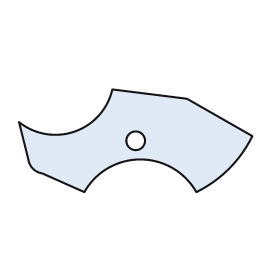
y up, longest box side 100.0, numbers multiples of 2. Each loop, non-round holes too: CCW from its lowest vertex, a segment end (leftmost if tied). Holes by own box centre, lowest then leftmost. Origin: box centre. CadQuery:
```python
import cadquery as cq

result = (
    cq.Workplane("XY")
    .moveTo(-22.0, -22.0)
    .threePointArc((2.0, -8.0), (26.0, -22.0))
    .threePointArc((40.0, -12.0), (50.0, 2.0))
    .lineTo(22.0, 18.0)
    .lineTo(-10.0, 22.0)
    .threePointArc((-26.0, 4.0), (-50.0, 8.0))
    .lineTo(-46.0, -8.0)
    .threePointArc((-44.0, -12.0), (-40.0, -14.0))
    .close()
    .moveTo(0.0, 0.0)
    .circle(4.0)
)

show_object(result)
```